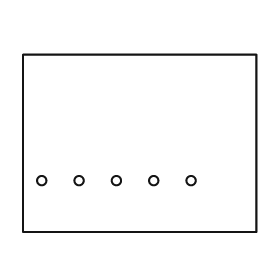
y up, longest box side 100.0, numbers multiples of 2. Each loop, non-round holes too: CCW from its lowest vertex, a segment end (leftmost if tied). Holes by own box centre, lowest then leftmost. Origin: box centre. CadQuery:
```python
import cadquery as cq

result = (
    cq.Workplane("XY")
    .moveTo(-50.0, -38.0)
    .lineTo(50.0, -38.0)
    .lineTo(50.0, 38.0)
    .lineTo(-50.0, 38.0)
    .close()
    .moveTo(-42.0, -16.0)
    .circle(2.0)
    .moveTo(-26.0, -16.0)
    .circle(2.0)
    .moveTo(-10.0, -16.0)
    .circle(2.0)
    .moveTo(6.0, -16.0)
    .circle(2.0)
    .moveTo(22.0, -16.0)
    .circle(2.0)
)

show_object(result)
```